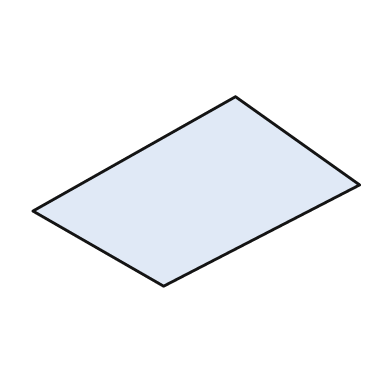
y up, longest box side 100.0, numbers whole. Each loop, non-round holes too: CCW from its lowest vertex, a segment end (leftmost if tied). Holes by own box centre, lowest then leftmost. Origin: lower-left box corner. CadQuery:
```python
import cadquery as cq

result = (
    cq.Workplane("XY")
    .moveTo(40.0, 0.0)
    .lineTo(100.0, 31.0)
    .lineTo(62.0, 58.0)
    .lineTo(0.0, 23.0)
    .close()
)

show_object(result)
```